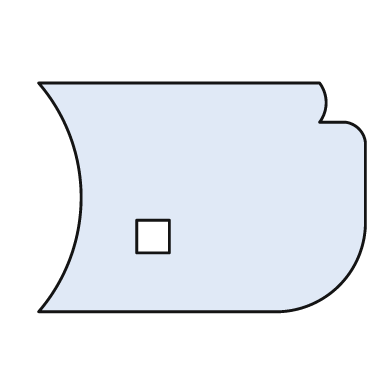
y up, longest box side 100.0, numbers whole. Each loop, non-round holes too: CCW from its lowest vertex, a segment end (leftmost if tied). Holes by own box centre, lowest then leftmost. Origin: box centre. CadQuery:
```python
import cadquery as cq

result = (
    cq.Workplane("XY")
    .moveTo(-50.0, -35.0)
    .lineTo(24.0, -35.0)
    .threePointArc((42.0, -27.0), (50.0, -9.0))
    .lineTo(50.0, 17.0)
    .threePointArc((48.0, 21.0), (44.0, 23.0))
    .lineTo(36.0, 23.0)
    .threePointArc((38.0, 29.0), (36.0, 35.0))
    .lineTo(-50.0, 35.0)
    .threePointArc((-37.0, 0.0), (-50.0, -35.0))
    .close()
    .moveTo(-20.0, -17.0)
    .lineTo(-10.0, -17.0)
    .lineTo(-10.0, -7.0)
    .lineTo(-20.0, -7.0)
    .close()
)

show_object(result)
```